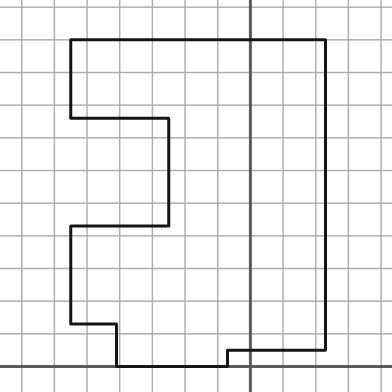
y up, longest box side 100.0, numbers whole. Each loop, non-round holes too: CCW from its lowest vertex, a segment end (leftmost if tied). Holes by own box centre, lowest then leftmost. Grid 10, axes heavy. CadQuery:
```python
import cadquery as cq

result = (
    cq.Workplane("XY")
    .moveTo(-41.0, 0.0)
    .lineTo(-7.0, 0.0)
    .lineTo(-7.0, 5.0)
    .lineTo(23.0, 5.0)
    .lineTo(23.0, 100.0)
    .lineTo(-55.0, 100.0)
    .lineTo(-55.0, 76.0)
    .lineTo(-25.0, 76.0)
    .lineTo(-25.0, 43.0)
    .lineTo(-55.0, 43.0)
    .lineTo(-55.0, 13.0)
    .lineTo(-41.0, 13.0)
    .close()
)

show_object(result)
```